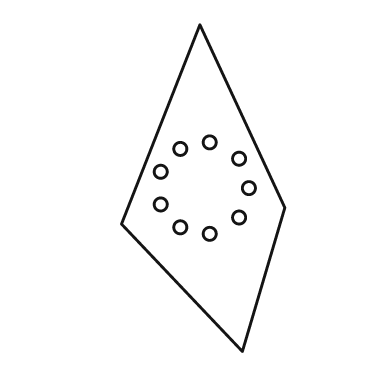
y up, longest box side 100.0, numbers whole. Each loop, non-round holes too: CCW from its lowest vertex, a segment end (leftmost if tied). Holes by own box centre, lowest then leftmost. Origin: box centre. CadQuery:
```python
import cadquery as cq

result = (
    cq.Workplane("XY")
    .moveTo(12.0, -50.0)
    .lineTo(25.0, -6.0)
    .lineTo(-1.0, 50.0)
    .lineTo(-25.0, -11.0)
    .close()
    .moveTo(2.0, -14.0)
    .circle(2.0)
    .moveTo(-7.0, -12.0)
    .circle(2.0)
    .moveTo(11.0, -9.0)
    .circle(2.0)
    .moveTo(-13.0, -5.0)
    .circle(2.0)
    .moveTo(14.0, 0.0)
    .circle(2.0)
    .moveTo(-13.0, 5.0)
    .circle(2.0)
    .moveTo(11.0, 9.0)
    .circle(2.0)
    .moveTo(-7.0, 12.0)
    .circle(2.0)
    .moveTo(2.0, 14.0)
    .circle(2.0)
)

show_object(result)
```